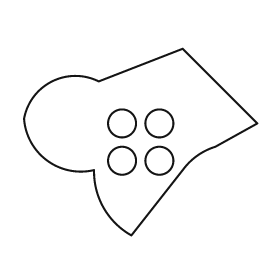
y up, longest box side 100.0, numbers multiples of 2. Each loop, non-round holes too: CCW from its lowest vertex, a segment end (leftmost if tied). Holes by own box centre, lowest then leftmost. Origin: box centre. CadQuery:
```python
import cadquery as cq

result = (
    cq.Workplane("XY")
    .moveTo(-4.0, -40.0)
    .lineTo(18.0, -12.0)
    .threePointArc((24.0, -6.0), (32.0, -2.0))
    .lineTo(50.0, 8.0)
    .lineTo(18.0, 40.0)
    .lineTo(-18.0, 26.0)
    .threePointArc((-38.0, 26.0), (-50.0, 10.0))
    .threePointArc((-40.0, -8.0), (-20.0, -12.0))
    .threePointArc((-16.0, -28.0), (-4.0, -40.0))
    .close()
    .moveTo(-8.0, -8.0)
    .circle(6.0)
    .moveTo(8.0, -8.0)
    .circle(6.0)
    .moveTo(-8.0, 8.0)
    .circle(6.0)
    .moveTo(8.0, 8.0)
    .circle(6.0)
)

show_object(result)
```